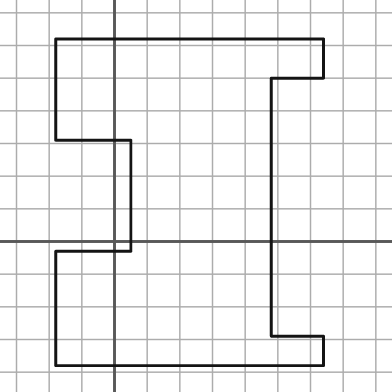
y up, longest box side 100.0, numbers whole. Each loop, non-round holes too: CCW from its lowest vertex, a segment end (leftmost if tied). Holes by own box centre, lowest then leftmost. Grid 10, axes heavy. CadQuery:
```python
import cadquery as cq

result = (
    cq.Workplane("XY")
    .moveTo(-18.0, -38.0)
    .lineTo(64.0, -38.0)
    .lineTo(64.0, -29.0)
    .lineTo(48.0, -29.0)
    .lineTo(48.0, 50.0)
    .lineTo(64.0, 50.0)
    .lineTo(64.0, 62.0)
    .lineTo(-18.0, 62.0)
    .lineTo(-18.0, 31.0)
    .lineTo(5.0, 31.0)
    .lineTo(5.0, -3.0)
    .lineTo(-18.0, -3.0)
    .close()
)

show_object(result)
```